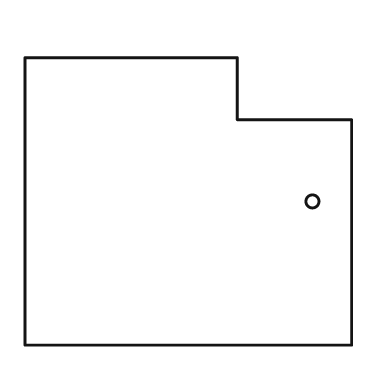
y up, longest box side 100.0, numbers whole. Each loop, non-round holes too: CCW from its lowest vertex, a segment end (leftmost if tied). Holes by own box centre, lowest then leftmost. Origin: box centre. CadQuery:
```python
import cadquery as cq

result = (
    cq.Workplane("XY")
    .moveTo(-50.0, -44.0)
    .lineTo(50.0, -44.0)
    .lineTo(50.0, 25.0)
    .lineTo(15.0, 25.0)
    .lineTo(15.0, 44.0)
    .lineTo(-50.0, 44.0)
    .close()
    .moveTo(38.0, 0.0)
    .circle(2.0)
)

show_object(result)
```